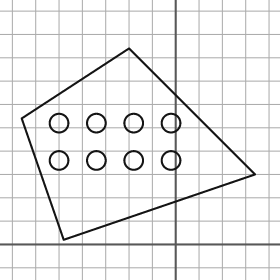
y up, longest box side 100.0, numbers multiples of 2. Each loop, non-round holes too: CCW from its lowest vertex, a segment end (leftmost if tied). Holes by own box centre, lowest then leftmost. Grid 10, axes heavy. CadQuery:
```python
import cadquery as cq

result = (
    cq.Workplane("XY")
    .moveTo(-48.0, 2.0)
    .lineTo(34.0, 30.0)
    .lineTo(-20.0, 84.0)
    .lineTo(-66.0, 54.0)
    .close()
    .moveTo(-50.0, 36.0)
    .circle(4.0)
    .moveTo(-34.0, 36.0)
    .circle(4.0)
    .moveTo(-18.0, 36.0)
    .circle(4.0)
    .moveTo(-2.0, 36.0)
    .circle(4.0)
    .moveTo(-50.0, 52.0)
    .circle(4.0)
    .moveTo(-34.0, 52.0)
    .circle(4.0)
    .moveTo(-18.0, 52.0)
    .circle(4.0)
    .moveTo(-2.0, 52.0)
    .circle(4.0)
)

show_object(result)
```